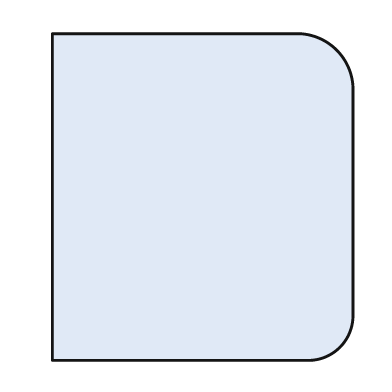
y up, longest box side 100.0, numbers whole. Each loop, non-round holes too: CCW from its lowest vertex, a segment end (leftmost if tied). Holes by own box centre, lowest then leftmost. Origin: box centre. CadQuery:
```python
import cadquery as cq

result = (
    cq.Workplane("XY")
    .moveTo(-46.0, -50.0)
    .lineTo(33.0, -50.0)
    .threePointArc((42.0, -46.0), (46.0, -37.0))
    .lineTo(46.0, 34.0)
    .threePointArc((41.0, 45.0), (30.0, 50.0))
    .lineTo(-46.0, 50.0)
    .close()
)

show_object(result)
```